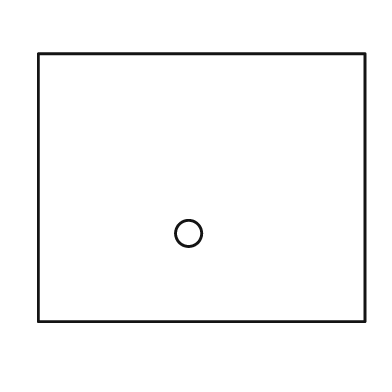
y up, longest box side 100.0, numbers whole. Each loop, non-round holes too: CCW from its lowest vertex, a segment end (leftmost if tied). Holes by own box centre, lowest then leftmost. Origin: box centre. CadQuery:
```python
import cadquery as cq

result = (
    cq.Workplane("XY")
    .moveTo(-50.0, -41.0)
    .lineTo(50.0, -41.0)
    .lineTo(50.0, 41.0)
    .lineTo(-50.0, 41.0)
    .close()
    .moveTo(-4.0, -14.0)
    .circle(4.0)
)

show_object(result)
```